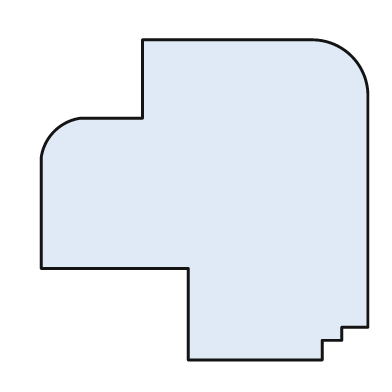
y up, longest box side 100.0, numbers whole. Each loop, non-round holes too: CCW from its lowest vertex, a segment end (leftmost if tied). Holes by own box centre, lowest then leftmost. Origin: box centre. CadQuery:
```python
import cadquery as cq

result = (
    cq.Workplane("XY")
    .moveTo(-5.0, -49.0)
    .lineTo(36.0, -49.0)
    .lineTo(36.0, -43.0)
    .lineTo(42.0, -43.0)
    .lineTo(42.0, -39.0)
    .lineTo(50.0, -39.0)
    .lineTo(50.0, 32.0)
    .threePointArc((45.0, 44.0), (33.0, 49.0))
    .lineTo(-19.0, 49.0)
    .lineTo(-19.0, 25.0)
    .lineTo(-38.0, 25.0)
    .threePointArc((-46.0, 21.0), (-50.0, 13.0))
    .lineTo(-50.0, -21.0)
    .lineTo(-5.0, -21.0)
    .close()
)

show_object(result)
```